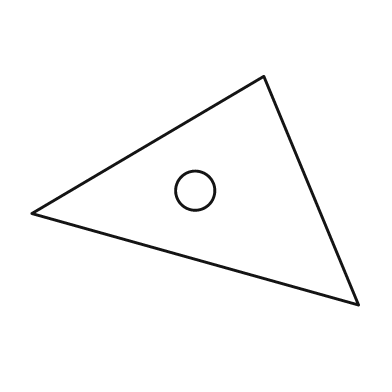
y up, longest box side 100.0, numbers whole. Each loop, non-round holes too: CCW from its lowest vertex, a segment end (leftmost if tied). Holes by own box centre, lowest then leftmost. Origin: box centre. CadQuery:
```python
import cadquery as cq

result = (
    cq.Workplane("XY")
    .moveTo(50.0, -35.0)
    .lineTo(21.0, 35.0)
    .lineTo(-50.0, -7.0)
    .close()
    .moveTo(0.0, 0.0)
    .circle(6.0)
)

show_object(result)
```